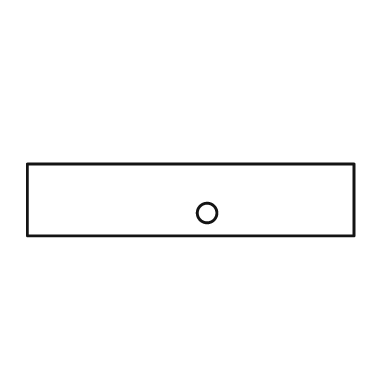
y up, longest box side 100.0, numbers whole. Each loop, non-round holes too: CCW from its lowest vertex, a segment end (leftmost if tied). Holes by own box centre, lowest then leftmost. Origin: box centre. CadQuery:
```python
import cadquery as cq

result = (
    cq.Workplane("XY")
    .moveTo(-50.0, -11.0)
    .lineTo(50.0, -11.0)
    .lineTo(50.0, 11.0)
    .lineTo(-50.0, 11.0)
    .close()
    .moveTo(5.0, -4.0)
    .circle(3.0)
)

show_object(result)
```